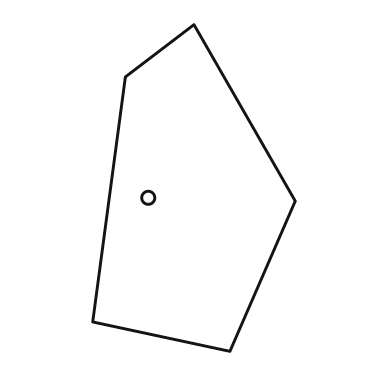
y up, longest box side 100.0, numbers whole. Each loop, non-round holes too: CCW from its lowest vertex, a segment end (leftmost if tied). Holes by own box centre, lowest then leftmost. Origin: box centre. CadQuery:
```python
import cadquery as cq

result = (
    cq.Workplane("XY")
    .moveTo(11.0, -50.0)
    .lineTo(31.0, -4.0)
    .lineTo(0.0, 50.0)
    .lineTo(-21.0, 34.0)
    .lineTo(-31.0, -41.0)
    .close()
    .moveTo(-14.0, -3.0)
    .circle(2.0)
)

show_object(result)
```